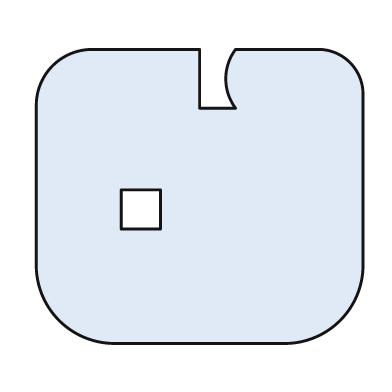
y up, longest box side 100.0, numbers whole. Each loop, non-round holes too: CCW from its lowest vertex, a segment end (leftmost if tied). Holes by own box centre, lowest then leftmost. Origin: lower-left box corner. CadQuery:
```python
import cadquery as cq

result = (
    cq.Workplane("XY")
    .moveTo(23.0, 0.0)
    .lineTo(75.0, 0.0)
    .threePointArc((93.0, 7.0), (100.0, 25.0))
    .lineTo(100.0, 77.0)
    .threePointArc((96.0, 86.0), (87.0, 90.0))
    .lineTo(61.0, 90.0)
    .threePointArc((58.0, 81.0), (61.0, 72.0))
    .lineTo(50.0, 72.0)
    .lineTo(50.0, 90.0)
    .lineTo(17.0, 90.0)
    .threePointArc((5.0, 85.0), (0.0, 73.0))
    .lineTo(0.0, 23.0)
    .threePointArc((7.0, 7.0), (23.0, 0.0))
    .close()
    .moveTo(26.0, 35.0)
    .lineTo(38.0, 35.0)
    .lineTo(38.0, 47.0)
    .lineTo(26.0, 47.0)
    .close()
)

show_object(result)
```